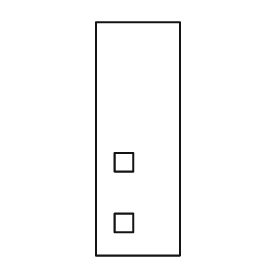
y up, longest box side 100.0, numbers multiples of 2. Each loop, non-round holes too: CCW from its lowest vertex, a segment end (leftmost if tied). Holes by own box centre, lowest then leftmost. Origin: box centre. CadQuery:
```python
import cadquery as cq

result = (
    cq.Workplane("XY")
    .moveTo(-18.0, -50.0)
    .lineTo(18.0, -50.0)
    .lineTo(18.0, 50.0)
    .lineTo(-18.0, 50.0)
    .close()
    .moveTo(-10.0, -40.0)
    .lineTo(-2.0, -40.0)
    .lineTo(-2.0, -32.0)
    .lineTo(-10.0, -32.0)
    .close()
    .moveTo(-10.0, -14.0)
    .lineTo(-2.0, -14.0)
    .lineTo(-2.0, -6.0)
    .lineTo(-10.0, -6.0)
    .close()
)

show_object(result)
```